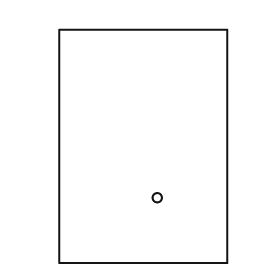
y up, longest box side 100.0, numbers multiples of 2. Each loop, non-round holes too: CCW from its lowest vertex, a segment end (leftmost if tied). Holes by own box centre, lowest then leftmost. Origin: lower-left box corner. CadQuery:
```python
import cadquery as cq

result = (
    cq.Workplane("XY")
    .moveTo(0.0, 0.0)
    .lineTo(72.0, 0.0)
    .lineTo(72.0, 100.0)
    .lineTo(0.0, 100.0)
    .close()
    .moveTo(42.0, 28.0)
    .circle(2.0)
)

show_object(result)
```